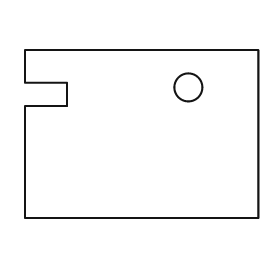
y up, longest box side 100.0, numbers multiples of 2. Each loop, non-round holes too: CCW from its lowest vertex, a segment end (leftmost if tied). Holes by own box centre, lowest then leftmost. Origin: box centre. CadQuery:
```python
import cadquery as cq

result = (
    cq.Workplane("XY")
    .moveTo(-50.0, -36.0)
    .lineTo(50.0, -36.0)
    .lineTo(50.0, 36.0)
    .lineTo(-50.0, 36.0)
    .lineTo(-50.0, 22.0)
    .lineTo(-32.0, 22.0)
    .lineTo(-32.0, 12.0)
    .lineTo(-50.0, 12.0)
    .close()
    .moveTo(20.0, 20.0)
    .circle(6.0)
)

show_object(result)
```